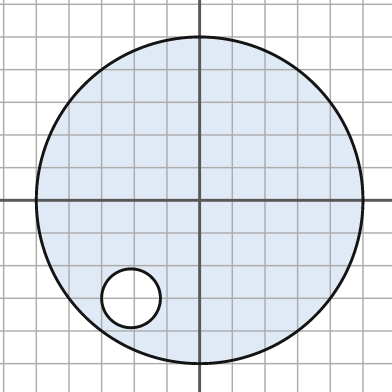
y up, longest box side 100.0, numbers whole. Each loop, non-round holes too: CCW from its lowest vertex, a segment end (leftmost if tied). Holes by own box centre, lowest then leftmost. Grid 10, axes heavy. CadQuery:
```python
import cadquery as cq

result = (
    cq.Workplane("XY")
    .moveTo(0.0, 0.0)
    .circle(50.0)
    .moveTo(-21.0, -30.0)
    .circle(9.0)
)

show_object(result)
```